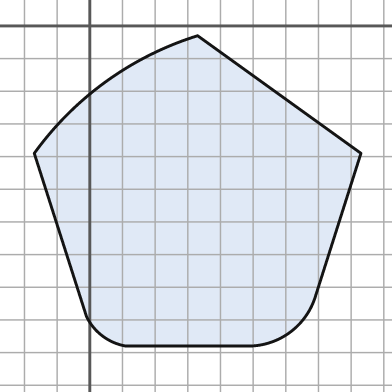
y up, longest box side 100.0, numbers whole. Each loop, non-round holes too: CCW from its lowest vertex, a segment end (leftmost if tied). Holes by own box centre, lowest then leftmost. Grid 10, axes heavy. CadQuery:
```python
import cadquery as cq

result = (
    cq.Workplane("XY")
    .moveTo(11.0, -98.0)
    .lineTo(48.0, -98.0)
    .threePointArc((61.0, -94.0), (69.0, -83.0))
    .lineTo(83.0, -39.0)
    .lineTo(33.0, -3.0)
    .threePointArc((5.0, -17.0), (-17.0, -39.0))
    .lineTo(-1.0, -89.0)
    .threePointArc((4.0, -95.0), (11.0, -98.0))
    .close()
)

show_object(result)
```